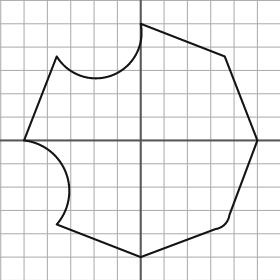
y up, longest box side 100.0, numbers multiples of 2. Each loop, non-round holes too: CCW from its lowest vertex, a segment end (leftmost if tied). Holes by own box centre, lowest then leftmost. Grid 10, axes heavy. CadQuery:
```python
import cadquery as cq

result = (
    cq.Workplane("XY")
    .moveTo(0.0, -50.0)
    .lineTo(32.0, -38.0)
    .threePointArc((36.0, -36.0), (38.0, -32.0))
    .lineTo(50.0, 0.0)
    .lineTo(36.0, 36.0)
    .lineTo(0.0, 50.0)
    .threePointArc((-12.0, 28.0), (-36.0, 36.0))
    .lineTo(-50.0, 0.0)
    .threePointArc((-32.0, -14.0), (-36.0, -36.0))
    .close()
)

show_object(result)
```